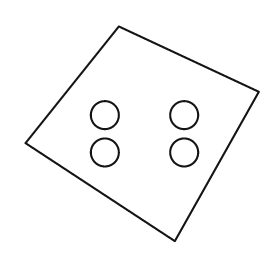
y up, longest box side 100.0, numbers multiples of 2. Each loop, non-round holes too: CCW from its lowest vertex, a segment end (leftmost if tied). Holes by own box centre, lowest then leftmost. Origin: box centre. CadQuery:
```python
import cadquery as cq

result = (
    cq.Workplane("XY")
    .moveTo(14.0, -46.0)
    .lineTo(50.0, 18.0)
    .lineTo(-10.0, 46.0)
    .lineTo(-50.0, -4.0)
    .close()
    .moveTo(-16.0, -8.0)
    .circle(6.0)
    .moveTo(18.0, -8.0)
    .circle(6.0)
    .moveTo(-16.0, 8.0)
    .circle(6.0)
    .moveTo(18.0, 8.0)
    .circle(6.0)
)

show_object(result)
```